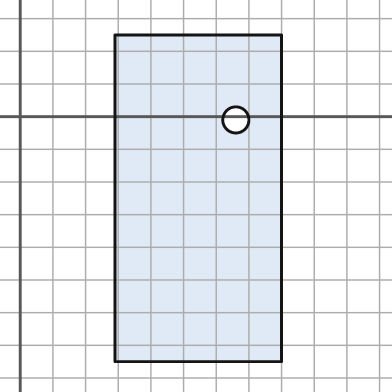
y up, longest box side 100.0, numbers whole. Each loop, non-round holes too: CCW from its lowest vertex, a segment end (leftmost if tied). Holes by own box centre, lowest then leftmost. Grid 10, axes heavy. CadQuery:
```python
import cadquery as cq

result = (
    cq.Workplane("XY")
    .moveTo(29.0, -75.0)
    .lineTo(80.0, -75.0)
    .lineTo(80.0, 25.0)
    .lineTo(29.0, 25.0)
    .close()
    .moveTo(66.0, -1.0)
    .circle(4.0)
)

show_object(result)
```